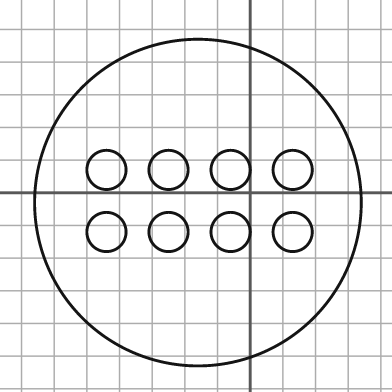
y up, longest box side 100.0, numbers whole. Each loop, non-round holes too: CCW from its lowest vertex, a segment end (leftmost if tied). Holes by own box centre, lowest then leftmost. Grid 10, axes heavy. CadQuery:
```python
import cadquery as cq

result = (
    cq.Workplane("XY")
    .moveTo(-16.0, -3.0)
    .circle(50.0)
    .moveTo(-44.0, -12.0)
    .circle(6.0)
    .moveTo(-25.0, -12.0)
    .circle(6.0)
    .moveTo(-6.0, -12.0)
    .circle(6.0)
    .moveTo(13.0, -12.0)
    .circle(6.0)
    .moveTo(-44.0, 7.0)
    .circle(6.0)
    .moveTo(-25.0, 7.0)
    .circle(6.0)
    .moveTo(-6.0, 7.0)
    .circle(6.0)
    .moveTo(13.0, 7.0)
    .circle(6.0)
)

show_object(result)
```